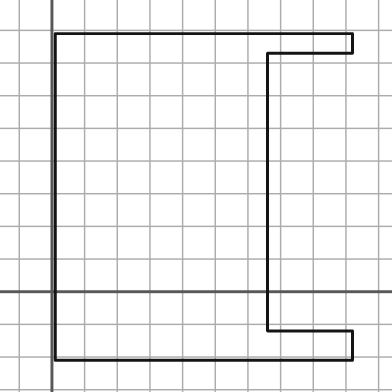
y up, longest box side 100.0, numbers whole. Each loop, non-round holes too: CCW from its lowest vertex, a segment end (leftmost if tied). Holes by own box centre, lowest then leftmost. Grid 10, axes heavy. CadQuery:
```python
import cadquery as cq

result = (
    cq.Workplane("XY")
    .moveTo(1.0, -21.0)
    .lineTo(92.0, -21.0)
    .lineTo(92.0, -12.0)
    .lineTo(66.0, -12.0)
    .lineTo(66.0, 73.0)
    .lineTo(92.0, 73.0)
    .lineTo(92.0, 79.0)
    .lineTo(1.0, 79.0)
    .close()
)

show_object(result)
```